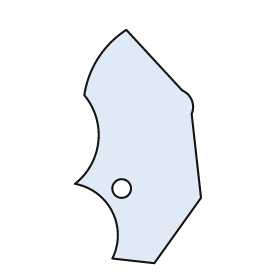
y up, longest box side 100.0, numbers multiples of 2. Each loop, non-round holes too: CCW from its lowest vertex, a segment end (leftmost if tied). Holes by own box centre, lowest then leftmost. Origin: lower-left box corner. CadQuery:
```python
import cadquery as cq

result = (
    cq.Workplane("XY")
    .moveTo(34.0, 0.0)
    .lineTo(54.0, 28.0)
    .lineTo(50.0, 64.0)
    .threePointArc((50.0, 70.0), (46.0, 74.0))
    .lineTo(22.0, 100.0)
    .threePointArc((10.0, 88.0), (4.0, 72.0))
    .threePointArc((10.0, 52.0), (0.0, 34.0))
    .threePointArc((16.0, 22.0), (16.0, 2.0))
    .close()
    .moveTo(20.0, 32.0)
    .circle(4.0)
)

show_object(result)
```